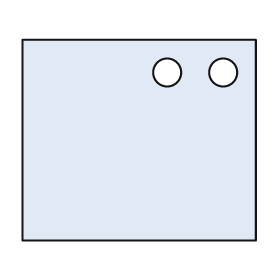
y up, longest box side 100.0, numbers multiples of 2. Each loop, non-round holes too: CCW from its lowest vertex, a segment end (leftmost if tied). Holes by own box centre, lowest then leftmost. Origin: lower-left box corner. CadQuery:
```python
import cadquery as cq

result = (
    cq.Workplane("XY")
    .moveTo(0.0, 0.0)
    .lineTo(100.0, 0.0)
    .lineTo(100.0, 86.0)
    .lineTo(0.0, 86.0)
    .close()
    .moveTo(62.0, 72.0)
    .circle(6.0)
    .moveTo(86.0, 72.0)
    .circle(6.0)
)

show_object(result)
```